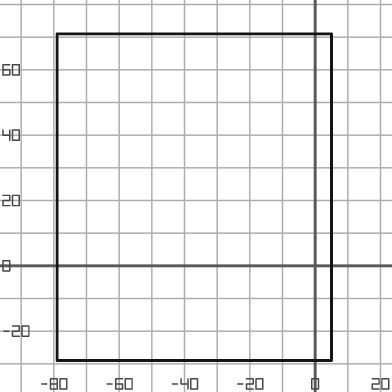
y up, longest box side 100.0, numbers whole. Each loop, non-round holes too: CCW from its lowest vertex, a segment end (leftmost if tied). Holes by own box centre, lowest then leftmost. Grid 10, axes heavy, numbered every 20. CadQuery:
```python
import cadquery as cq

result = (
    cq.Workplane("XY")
    .moveTo(-79.0, -29.0)
    .lineTo(5.0, -29.0)
    .lineTo(5.0, 71.0)
    .lineTo(-79.0, 71.0)
    .close()
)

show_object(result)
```